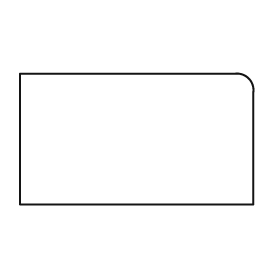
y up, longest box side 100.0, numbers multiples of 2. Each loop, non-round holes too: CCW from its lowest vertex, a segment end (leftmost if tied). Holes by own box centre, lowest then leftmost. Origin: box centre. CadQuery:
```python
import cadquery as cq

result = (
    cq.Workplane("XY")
    .moveTo(-50.0, -28.0)
    .lineTo(50.0, -28.0)
    .lineTo(50.0, 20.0)
    .threePointArc((48.0, 26.0), (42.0, 28.0))
    .lineTo(-50.0, 28.0)
    .close()
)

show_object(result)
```